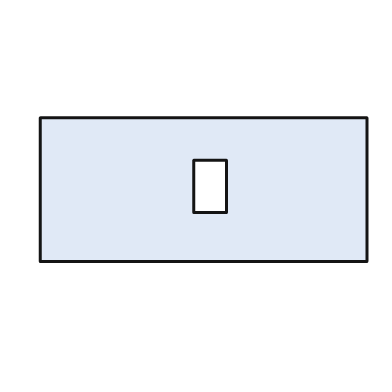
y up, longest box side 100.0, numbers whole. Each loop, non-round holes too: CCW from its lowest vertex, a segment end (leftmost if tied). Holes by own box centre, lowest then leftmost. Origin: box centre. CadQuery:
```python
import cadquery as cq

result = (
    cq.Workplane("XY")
    .moveTo(-50.0, -22.0)
    .lineTo(50.0, -22.0)
    .lineTo(50.0, 22.0)
    .lineTo(-50.0, 22.0)
    .close()
    .moveTo(-3.0, -7.0)
    .lineTo(7.0, -7.0)
    .lineTo(7.0, 9.0)
    .lineTo(-3.0, 9.0)
    .close()
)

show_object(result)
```